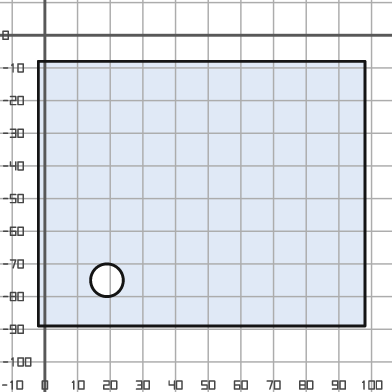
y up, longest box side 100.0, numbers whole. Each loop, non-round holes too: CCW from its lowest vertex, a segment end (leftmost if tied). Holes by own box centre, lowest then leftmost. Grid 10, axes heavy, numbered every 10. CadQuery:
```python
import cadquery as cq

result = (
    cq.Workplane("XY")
    .moveTo(-2.0, -89.0)
    .lineTo(98.0, -89.0)
    .lineTo(98.0, -8.0)
    .lineTo(-2.0, -8.0)
    .close()
    .moveTo(19.0, -75.0)
    .circle(5.0)
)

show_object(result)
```